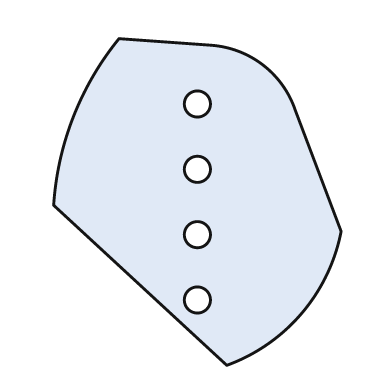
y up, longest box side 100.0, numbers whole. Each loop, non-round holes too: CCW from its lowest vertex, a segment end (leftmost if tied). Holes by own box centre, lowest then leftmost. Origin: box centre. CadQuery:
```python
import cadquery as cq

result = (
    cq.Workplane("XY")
    .moveTo(9.0, -50.0)
    .threePointArc((32.0, -34.0), (44.0, -9.0))
    .lineTo(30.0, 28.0)
    .threePointArc((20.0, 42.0), (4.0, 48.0))
    .lineTo(-24.0, 50.0)
    .threePointArc((-38.0, 26.0), (-44.0, -1.0))
    .close()
    .moveTo(0.0, -30.0)
    .circle(4.0)
    .moveTo(0.0, -10.0)
    .circle(4.0)
    .moveTo(0.0, 10.0)
    .circle(4.0)
    .moveTo(0.0, 30.0)
    .circle(4.0)
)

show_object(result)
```